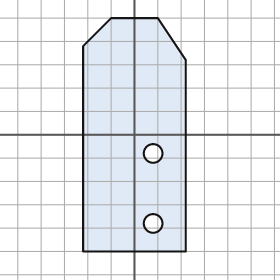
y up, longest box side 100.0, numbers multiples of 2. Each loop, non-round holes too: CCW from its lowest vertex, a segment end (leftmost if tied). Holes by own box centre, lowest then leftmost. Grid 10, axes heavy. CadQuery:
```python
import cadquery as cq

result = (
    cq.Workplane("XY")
    .moveTo(-22.0, -50.0)
    .lineTo(22.0, -50.0)
    .lineTo(22.0, 32.0)
    .lineTo(10.0, 50.0)
    .lineTo(-10.0, 50.0)
    .lineTo(-22.0, 38.0)
    .close()
    .moveTo(8.0, -38.0)
    .circle(4.0)
    .moveTo(8.0, -8.0)
    .circle(4.0)
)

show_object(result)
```